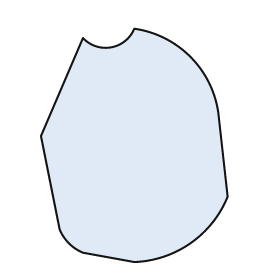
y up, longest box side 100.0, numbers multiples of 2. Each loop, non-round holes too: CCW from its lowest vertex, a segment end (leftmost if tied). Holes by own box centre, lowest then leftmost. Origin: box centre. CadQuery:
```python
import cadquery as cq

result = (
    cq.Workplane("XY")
    .moveTo(0.0, -50.0)
    .threePointArc((24.0, -42.0), (40.0, -22.0))
    .lineTo(36.0, 14.0)
    .threePointArc((24.0, 38.0), (0.0, 50.0))
    .threePointArc((-10.0, 42.0), (-22.0, 46.0))
    .lineTo(-40.0, 4.0)
    .lineTo(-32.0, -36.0)
    .threePointArc((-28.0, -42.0), (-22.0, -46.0))
    .close()
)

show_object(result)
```